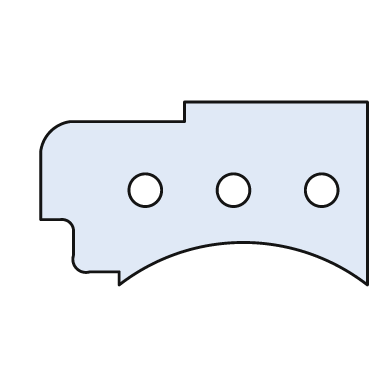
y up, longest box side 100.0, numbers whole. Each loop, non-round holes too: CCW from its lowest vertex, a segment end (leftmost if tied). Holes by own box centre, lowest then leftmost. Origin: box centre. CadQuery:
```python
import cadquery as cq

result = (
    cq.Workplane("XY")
    .moveTo(-26.0, -28.0)
    .threePointArc((12.0, -15.0), (50.0, -28.0))
    .lineTo(50.0, 28.0)
    .lineTo(-6.0, 28.0)
    .lineTo(-6.0, 22.0)
    .lineTo(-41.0, 22.0)
    .threePointArc((-47.0, 19.0), (-50.0, 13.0))
    .lineTo(-50.0, -8.0)
    .lineTo(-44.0, -8.0)
    .threePointArc((-41.0, -9.0), (-40.0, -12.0))
    .lineTo(-40.0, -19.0)
    .threePointArc((-39.0, -23.0), (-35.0, -24.0))
    .lineTo(-26.0, -24.0)
    .close()
    .moveTo(-18.0, 1.0)
    .circle(5.0)
    .moveTo(9.0, 1.0)
    .circle(5.0)
    .moveTo(36.0, 1.0)
    .circle(5.0)
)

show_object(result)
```